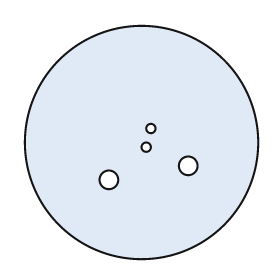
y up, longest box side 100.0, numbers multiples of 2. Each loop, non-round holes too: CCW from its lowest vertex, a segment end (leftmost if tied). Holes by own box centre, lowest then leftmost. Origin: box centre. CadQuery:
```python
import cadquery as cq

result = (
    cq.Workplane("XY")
    .moveTo(0.0, 0.0)
    .circle(50.0)
    .moveTo(-14.0, -16.0)
    .circle(4.0)
    .moveTo(20.0, -10.0)
    .circle(4.0)
    .moveTo(2.0, -2.0)
    .circle(2.0)
    .moveTo(4.0, 6.0)
    .circle(2.0)
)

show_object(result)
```